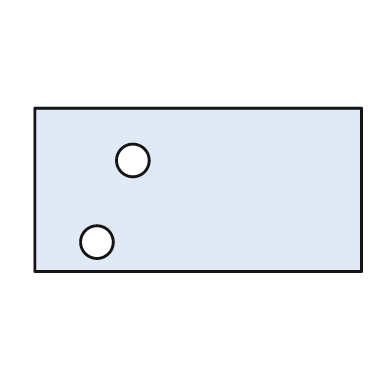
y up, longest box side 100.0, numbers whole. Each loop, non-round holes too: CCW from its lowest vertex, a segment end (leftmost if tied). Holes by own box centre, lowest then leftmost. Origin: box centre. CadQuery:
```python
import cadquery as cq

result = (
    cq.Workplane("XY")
    .moveTo(-50.0, -25.0)
    .lineTo(50.0, -25.0)
    .lineTo(50.0, 25.0)
    .lineTo(-50.0, 25.0)
    .close()
    .moveTo(-31.0, -16.0)
    .circle(5.0)
    .moveTo(-20.0, 9.0)
    .circle(5.0)
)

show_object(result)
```